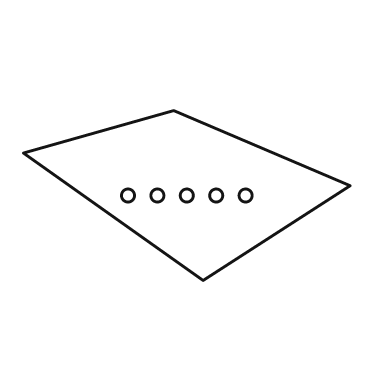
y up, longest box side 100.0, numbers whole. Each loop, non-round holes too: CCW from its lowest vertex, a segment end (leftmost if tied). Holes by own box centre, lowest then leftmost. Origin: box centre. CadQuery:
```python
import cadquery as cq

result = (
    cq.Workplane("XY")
    .moveTo(5.0, -26.0)
    .lineTo(50.0, 3.0)
    .lineTo(-4.0, 26.0)
    .lineTo(-50.0, 13.0)
    .close()
    .moveTo(-18.0, 0.0)
    .circle(2.0)
    .moveTo(-9.0, 0.0)
    .circle(2.0)
    .moveTo(0.0, 0.0)
    .circle(2.0)
    .moveTo(9.0, 0.0)
    .circle(2.0)
    .moveTo(18.0, 0.0)
    .circle(2.0)
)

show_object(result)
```